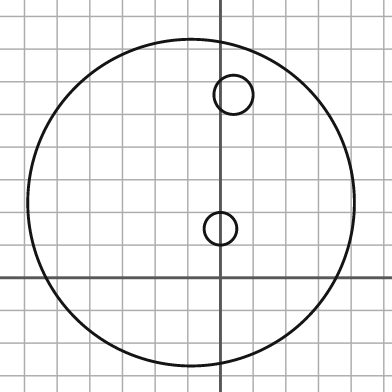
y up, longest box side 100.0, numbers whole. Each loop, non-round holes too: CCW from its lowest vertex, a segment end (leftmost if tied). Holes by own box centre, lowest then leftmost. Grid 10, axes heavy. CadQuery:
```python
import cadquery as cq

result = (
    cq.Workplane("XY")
    .moveTo(-9.0, 23.0)
    .circle(50.0)
    .moveTo(0.0, 15.0)
    .circle(5.0)
    .moveTo(4.0, 56.0)
    .circle(6.0)
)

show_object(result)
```